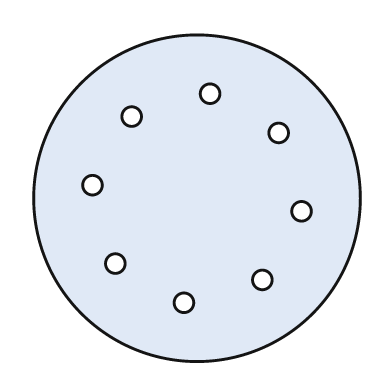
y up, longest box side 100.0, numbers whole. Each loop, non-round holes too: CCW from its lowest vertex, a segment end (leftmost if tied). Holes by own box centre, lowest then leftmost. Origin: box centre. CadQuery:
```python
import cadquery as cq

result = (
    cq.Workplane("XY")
    .moveTo(0.0, 0.0)
    .circle(50.0)
    .moveTo(-4.0, -32.0)
    .circle(3.0)
    .moveTo(20.0, -25.0)
    .circle(3.0)
    .moveTo(-25.0, -20.0)
    .circle(3.0)
    .moveTo(32.0, -4.0)
    .circle(3.0)
    .moveTo(-32.0, 4.0)
    .circle(3.0)
    .moveTo(25.0, 20.0)
    .circle(3.0)
    .moveTo(-20.0, 25.0)
    .circle(3.0)
    .moveTo(4.0, 32.0)
    .circle(3.0)
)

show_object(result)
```